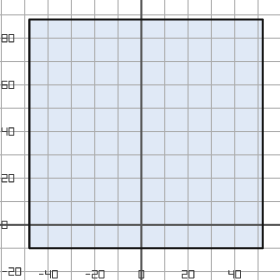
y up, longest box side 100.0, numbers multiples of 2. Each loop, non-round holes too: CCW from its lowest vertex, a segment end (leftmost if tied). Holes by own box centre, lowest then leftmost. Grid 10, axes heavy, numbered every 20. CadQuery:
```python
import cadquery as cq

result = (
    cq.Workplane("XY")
    .moveTo(-48.0, -10.0)
    .lineTo(52.0, -10.0)
    .lineTo(52.0, 88.0)
    .lineTo(-48.0, 88.0)
    .close()
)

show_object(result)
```